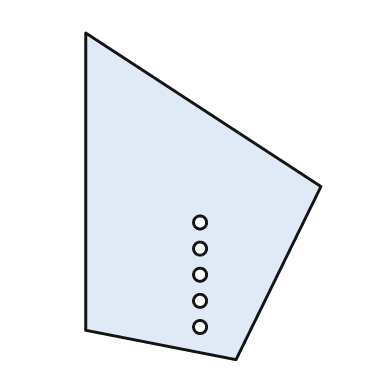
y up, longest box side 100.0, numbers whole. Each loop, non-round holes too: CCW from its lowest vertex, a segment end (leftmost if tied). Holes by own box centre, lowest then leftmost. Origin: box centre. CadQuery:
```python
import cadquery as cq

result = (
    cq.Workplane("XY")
    .moveTo(10.0, -50.0)
    .lineTo(36.0, 3.0)
    .lineTo(-36.0, 50.0)
    .lineTo(-36.0, -41.0)
    .close()
    .moveTo(-1.0, -40.0)
    .circle(2.0)
    .moveTo(-1.0, -32.0)
    .circle(2.0)
    .moveTo(-1.0, -24.0)
    .circle(2.0)
    .moveTo(-1.0, -16.0)
    .circle(2.0)
    .moveTo(-1.0, -8.0)
    .circle(2.0)
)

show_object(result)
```